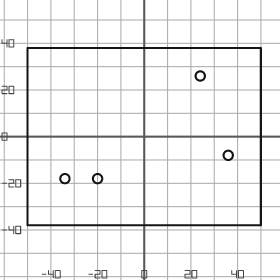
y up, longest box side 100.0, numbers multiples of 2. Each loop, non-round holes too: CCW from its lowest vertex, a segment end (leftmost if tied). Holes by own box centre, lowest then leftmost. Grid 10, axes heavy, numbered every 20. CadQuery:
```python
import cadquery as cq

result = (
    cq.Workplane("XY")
    .moveTo(-50.0, -38.0)
    .lineTo(50.0, -38.0)
    .lineTo(50.0, 38.0)
    .lineTo(-50.0, 38.0)
    .close()
    .moveTo(-34.0, -18.0)
    .circle(2.0)
    .moveTo(-20.0, -18.0)
    .circle(2.0)
    .moveTo(36.0, -8.0)
    .circle(2.0)
    .moveTo(24.0, 26.0)
    .circle(2.0)
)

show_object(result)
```